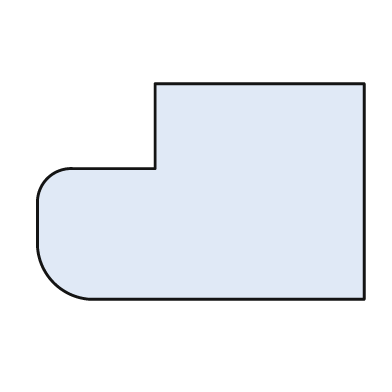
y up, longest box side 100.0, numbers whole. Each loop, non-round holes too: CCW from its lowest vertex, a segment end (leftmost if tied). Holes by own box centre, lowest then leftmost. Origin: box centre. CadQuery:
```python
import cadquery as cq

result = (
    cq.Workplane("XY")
    .moveTo(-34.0, -33.0)
    .lineTo(50.0, -33.0)
    .lineTo(50.0, 33.0)
    .lineTo(-14.0, 33.0)
    .lineTo(-14.0, 7.0)
    .lineTo(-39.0, 7.0)
    .threePointArc((-47.0, 4.0), (-50.0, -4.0))
    .lineTo(-50.0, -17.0)
    .threePointArc((-45.0, -28.0), (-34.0, -33.0))
    .close()
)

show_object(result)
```